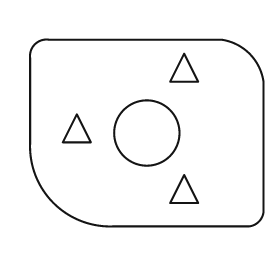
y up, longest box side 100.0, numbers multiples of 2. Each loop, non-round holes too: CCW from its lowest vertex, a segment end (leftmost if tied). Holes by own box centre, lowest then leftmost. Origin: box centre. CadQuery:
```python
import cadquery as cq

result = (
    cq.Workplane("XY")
    .moveTo(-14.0, -40.0)
    .lineTo(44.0, -40.0)
    .threePointArc((48.0, -38.0), (50.0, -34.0))
    .lineTo(50.0, 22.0)
    .threePointArc((44.0, 34.0), (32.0, 40.0))
    .lineTo(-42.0, 40.0)
    .threePointArc((-48.0, 38.0), (-50.0, 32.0))
    .lineTo(-50.0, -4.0)
    .threePointArc((-40.0, -30.0), (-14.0, -40.0))
    .close()
    .moveTo(10.0, -30.0)
    .lineTo(22.0, -30.0)
    .lineTo(16.0, -18.0)
    .close()
    .moveTo(0.0, 0.0)
    .circle(14.0)
    .moveTo(-36.0, -4.0)
    .lineTo(-24.0, -4.0)
    .lineTo(-30.0, 8.0)
    .close()
    .moveTo(10.0, 22.0)
    .lineTo(22.0, 22.0)
    .lineTo(16.0, 34.0)
    .close()
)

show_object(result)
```